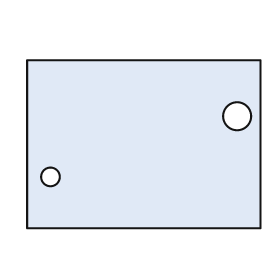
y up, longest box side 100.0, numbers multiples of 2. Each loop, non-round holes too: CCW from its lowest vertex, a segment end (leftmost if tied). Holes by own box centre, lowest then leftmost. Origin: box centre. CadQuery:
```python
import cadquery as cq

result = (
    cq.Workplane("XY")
    .moveTo(-50.0, -36.0)
    .lineTo(50.0, -36.0)
    .lineTo(50.0, 36.0)
    .lineTo(-50.0, 36.0)
    .close()
    .moveTo(-40.0, -14.0)
    .circle(4.0)
    .moveTo(40.0, 12.0)
    .circle(6.0)
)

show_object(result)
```